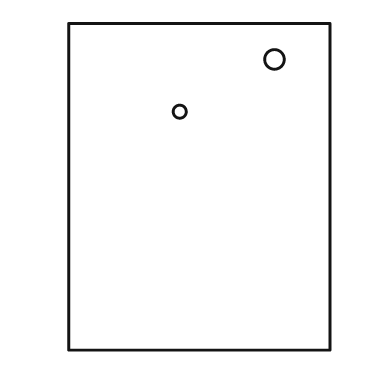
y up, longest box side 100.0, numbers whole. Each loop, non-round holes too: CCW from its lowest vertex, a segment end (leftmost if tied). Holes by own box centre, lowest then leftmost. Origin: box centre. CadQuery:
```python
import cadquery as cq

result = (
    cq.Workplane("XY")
    .moveTo(-40.0, -50.0)
    .lineTo(40.0, -50.0)
    .lineTo(40.0, 50.0)
    .lineTo(-40.0, 50.0)
    .close()
    .moveTo(-6.0, 23.0)
    .circle(2.0)
    .moveTo(23.0, 39.0)
    .circle(3.0)
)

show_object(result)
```